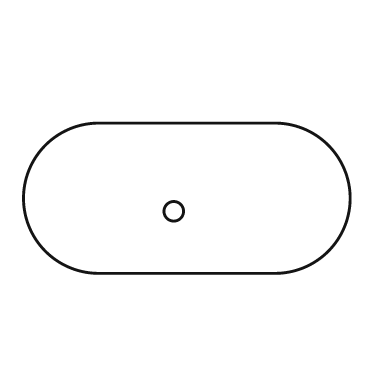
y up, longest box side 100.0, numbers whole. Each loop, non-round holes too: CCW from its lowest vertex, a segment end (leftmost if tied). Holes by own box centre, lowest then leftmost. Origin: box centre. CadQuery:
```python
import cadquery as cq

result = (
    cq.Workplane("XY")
    .moveTo(-27.0, -23.0)
    .lineTo(27.0, -23.0)
    .threePointArc((50.0, 0.0), (27.0, 23.0))
    .lineTo(-27.0, 23.0)
    .threePointArc((-50.0, 0.0), (-27.0, -23.0))
    .close()
    .moveTo(-4.0, -4.0)
    .circle(3.0)
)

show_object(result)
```